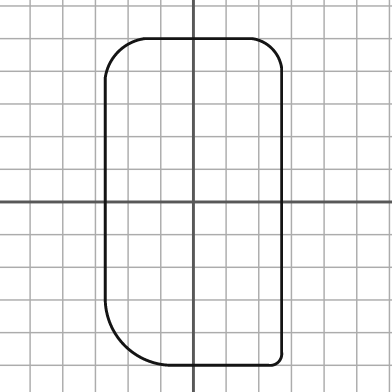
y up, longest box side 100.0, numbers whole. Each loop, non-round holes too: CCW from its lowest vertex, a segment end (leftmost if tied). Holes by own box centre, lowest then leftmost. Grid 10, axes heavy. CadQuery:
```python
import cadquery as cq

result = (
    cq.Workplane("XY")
    .moveTo(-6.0, -50.0)
    .lineTo(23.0, -50.0)
    .threePointArc((26.0, -49.0), (27.0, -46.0))
    .lineTo(27.0, 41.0)
    .threePointArc((24.0, 47.0), (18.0, 50.0))
    .lineTo(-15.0, 50.0)
    .threePointArc((-23.0, 46.0), (-27.0, 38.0))
    .lineTo(-27.0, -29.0)
    .threePointArc((-21.0, -44.0), (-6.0, -50.0))
    .close()
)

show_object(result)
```